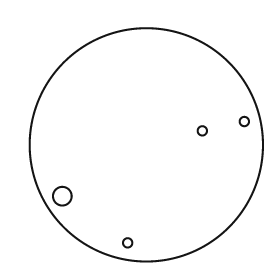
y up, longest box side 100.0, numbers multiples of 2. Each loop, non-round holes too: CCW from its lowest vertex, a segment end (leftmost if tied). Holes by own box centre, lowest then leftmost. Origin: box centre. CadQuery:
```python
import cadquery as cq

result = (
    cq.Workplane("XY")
    .moveTo(0.0, 0.0)
    .circle(50.0)
    .moveTo(-8.0, -42.0)
    .circle(2.0)
    .moveTo(-36.0, -22.0)
    .circle(4.0)
    .moveTo(24.0, 6.0)
    .circle(2.0)
    .moveTo(42.0, 10.0)
    .circle(2.0)
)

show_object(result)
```